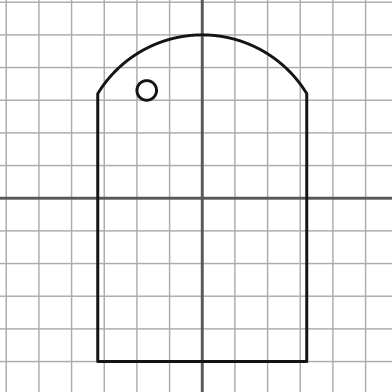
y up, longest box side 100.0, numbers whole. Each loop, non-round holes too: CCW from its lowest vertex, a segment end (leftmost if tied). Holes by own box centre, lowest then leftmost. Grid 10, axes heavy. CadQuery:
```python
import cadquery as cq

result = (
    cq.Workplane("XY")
    .moveTo(-32.0, -50.0)
    .lineTo(32.0, -50.0)
    .lineTo(32.0, 32.0)
    .threePointArc((0.0, 50.0), (-32.0, 32.0))
    .close()
    .moveTo(-17.0, 33.0)
    .circle(3.0)
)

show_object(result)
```